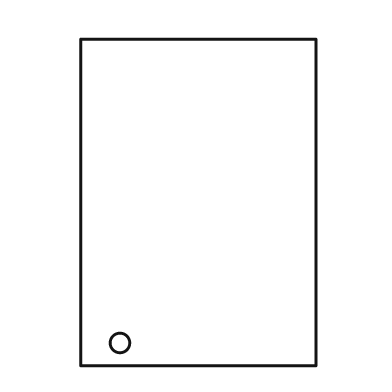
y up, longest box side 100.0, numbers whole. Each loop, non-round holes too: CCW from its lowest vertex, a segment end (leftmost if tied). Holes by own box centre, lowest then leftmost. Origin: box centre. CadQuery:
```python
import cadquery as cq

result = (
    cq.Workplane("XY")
    .moveTo(-36.0, -50.0)
    .lineTo(36.0, -50.0)
    .lineTo(36.0, 50.0)
    .lineTo(-36.0, 50.0)
    .close()
    .moveTo(-24.0, -43.0)
    .circle(3.0)
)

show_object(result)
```